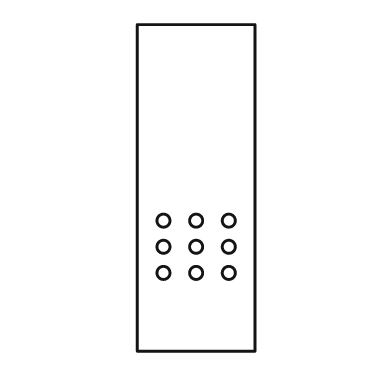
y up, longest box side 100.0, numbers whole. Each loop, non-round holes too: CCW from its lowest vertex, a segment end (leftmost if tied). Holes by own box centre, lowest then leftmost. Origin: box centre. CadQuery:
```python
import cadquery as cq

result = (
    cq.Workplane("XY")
    .moveTo(-18.0, -50.0)
    .lineTo(18.0, -50.0)
    .lineTo(18.0, 50.0)
    .lineTo(-18.0, 50.0)
    .close()
    .moveTo(-10.0, -26.0)
    .circle(2.0)
    .moveTo(0.0, -26.0)
    .circle(2.0)
    .moveTo(10.0, -26.0)
    .circle(2.0)
    .moveTo(-10.0, -18.0)
    .circle(2.0)
    .moveTo(0.0, -18.0)
    .circle(2.0)
    .moveTo(10.0, -18.0)
    .circle(2.0)
    .moveTo(-10.0, -10.0)
    .circle(2.0)
    .moveTo(0.0, -10.0)
    .circle(2.0)
    .moveTo(10.0, -10.0)
    .circle(2.0)
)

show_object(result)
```